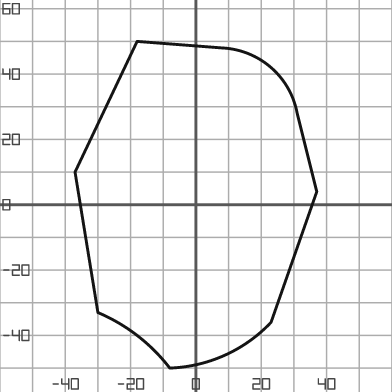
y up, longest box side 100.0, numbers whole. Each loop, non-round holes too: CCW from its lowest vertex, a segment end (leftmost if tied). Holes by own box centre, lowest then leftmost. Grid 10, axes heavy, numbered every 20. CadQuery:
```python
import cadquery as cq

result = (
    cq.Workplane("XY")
    .moveTo(-8.0, -50.0)
    .threePointArc((9.0, -46.0), (23.0, -36.0))
    .lineTo(37.0, 4.0)
    .lineTo(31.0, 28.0)
    .threePointArc((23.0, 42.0), (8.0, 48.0))
    .lineTo(-18.0, 50.0)
    .lineTo(-37.0, 10.0)
    .lineTo(-30.0, -33.0)
    .threePointArc((-18.0, -40.0), (-8.0, -50.0))
    .close()
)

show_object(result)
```